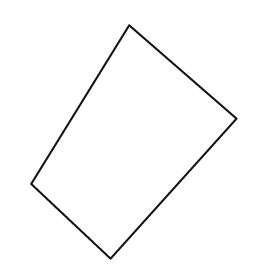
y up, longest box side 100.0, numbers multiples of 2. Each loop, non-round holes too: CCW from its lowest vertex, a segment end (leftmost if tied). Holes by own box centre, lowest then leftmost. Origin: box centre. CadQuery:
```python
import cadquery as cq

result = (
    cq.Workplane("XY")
    .moveTo(-10.0, -50.0)
    .lineTo(44.0, 10.0)
    .lineTo(-2.0, 50.0)
    .lineTo(-44.0, -18.0)
    .close()
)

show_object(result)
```